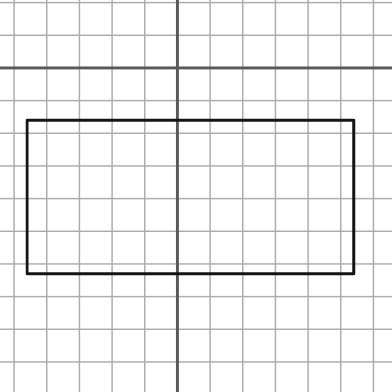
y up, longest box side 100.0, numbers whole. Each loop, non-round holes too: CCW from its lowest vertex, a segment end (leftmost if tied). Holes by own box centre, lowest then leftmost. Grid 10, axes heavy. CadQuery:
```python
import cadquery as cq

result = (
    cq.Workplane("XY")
    .moveTo(-46.0, -63.0)
    .lineTo(54.0, -63.0)
    .lineTo(54.0, -16.0)
    .lineTo(-46.0, -16.0)
    .close()
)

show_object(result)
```